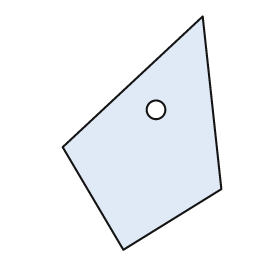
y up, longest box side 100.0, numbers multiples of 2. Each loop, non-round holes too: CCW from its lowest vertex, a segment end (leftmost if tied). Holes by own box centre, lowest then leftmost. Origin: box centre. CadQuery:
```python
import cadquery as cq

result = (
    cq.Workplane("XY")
    .moveTo(-8.0, -50.0)
    .lineTo(34.0, -24.0)
    .lineTo(26.0, 50.0)
    .lineTo(-34.0, -6.0)
    .close()
    .moveTo(6.0, 10.0)
    .circle(4.0)
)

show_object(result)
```